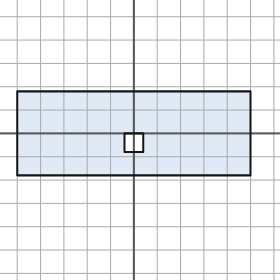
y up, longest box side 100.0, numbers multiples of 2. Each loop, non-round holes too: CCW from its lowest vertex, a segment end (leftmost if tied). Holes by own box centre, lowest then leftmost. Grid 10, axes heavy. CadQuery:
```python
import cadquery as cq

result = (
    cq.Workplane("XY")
    .moveTo(-50.0, -18.0)
    .lineTo(50.0, -18.0)
    .lineTo(50.0, 18.0)
    .lineTo(-50.0, 18.0)
    .close()
    .moveTo(-4.0, -8.0)
    .lineTo(4.0, -8.0)
    .lineTo(4.0, 0.0)
    .lineTo(-4.0, 0.0)
    .close()
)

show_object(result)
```